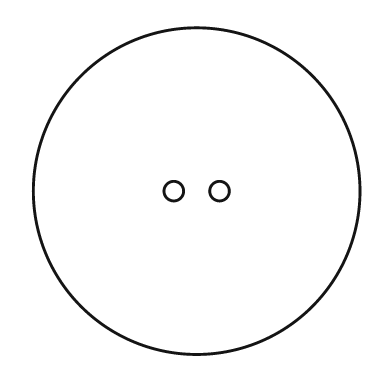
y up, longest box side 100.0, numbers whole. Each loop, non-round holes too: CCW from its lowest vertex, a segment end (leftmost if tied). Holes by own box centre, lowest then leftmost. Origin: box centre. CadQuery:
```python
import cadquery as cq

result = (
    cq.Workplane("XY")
    .moveTo(0.0, 0.0)
    .circle(50.0)
    .moveTo(-7.0, 0.0)
    .circle(3.0)
    .moveTo(7.0, 0.0)
    .circle(3.0)
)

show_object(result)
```